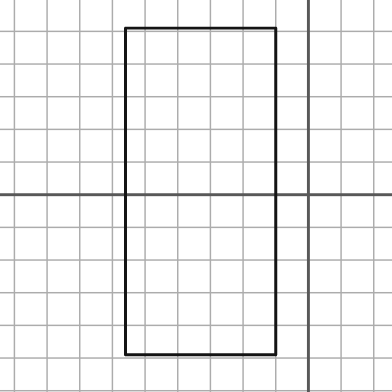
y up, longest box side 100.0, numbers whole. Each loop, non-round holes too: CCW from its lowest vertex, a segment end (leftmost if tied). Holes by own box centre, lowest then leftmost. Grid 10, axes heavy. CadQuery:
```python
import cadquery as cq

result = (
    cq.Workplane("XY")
    .moveTo(-56.0, -49.0)
    .lineTo(-10.0, -49.0)
    .lineTo(-10.0, 51.0)
    .lineTo(-56.0, 51.0)
    .close()
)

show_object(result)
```